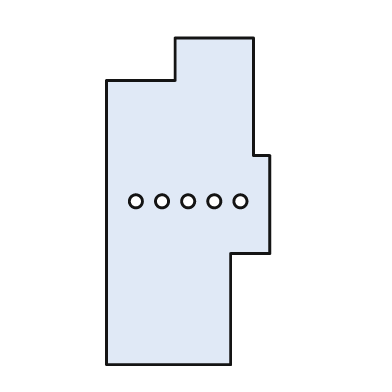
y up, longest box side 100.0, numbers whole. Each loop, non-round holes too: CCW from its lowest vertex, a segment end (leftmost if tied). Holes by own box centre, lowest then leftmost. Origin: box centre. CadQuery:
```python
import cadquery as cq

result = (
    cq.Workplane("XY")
    .moveTo(-25.0, -50.0)
    .lineTo(13.0, -50.0)
    .lineTo(13.0, -16.0)
    .lineTo(25.0, -16.0)
    .lineTo(25.0, 14.0)
    .lineTo(20.0, 14.0)
    .lineTo(20.0, 50.0)
    .lineTo(-4.0, 50.0)
    .lineTo(-4.0, 37.0)
    .lineTo(-25.0, 37.0)
    .close()
    .moveTo(-16.0, 0.0)
    .circle(2.0)
    .moveTo(-8.0, 0.0)
    .circle(2.0)
    .moveTo(0.0, 0.0)
    .circle(2.0)
    .moveTo(8.0, 0.0)
    .circle(2.0)
    .moveTo(16.0, 0.0)
    .circle(2.0)
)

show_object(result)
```